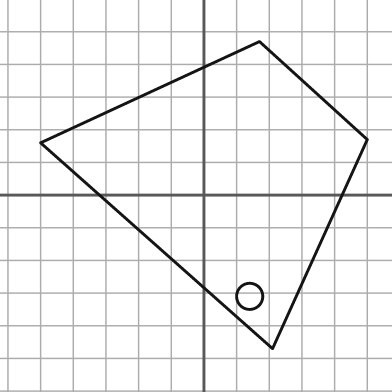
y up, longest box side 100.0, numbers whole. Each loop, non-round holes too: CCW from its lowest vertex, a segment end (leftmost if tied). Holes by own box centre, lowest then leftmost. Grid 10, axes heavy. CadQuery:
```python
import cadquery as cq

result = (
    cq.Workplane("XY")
    .moveTo(21.0, -47.0)
    .lineTo(50.0, 17.0)
    .lineTo(17.0, 47.0)
    .lineTo(-50.0, 16.0)
    .close()
    .moveTo(14.0, -31.0)
    .circle(4.0)
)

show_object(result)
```